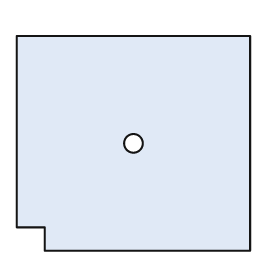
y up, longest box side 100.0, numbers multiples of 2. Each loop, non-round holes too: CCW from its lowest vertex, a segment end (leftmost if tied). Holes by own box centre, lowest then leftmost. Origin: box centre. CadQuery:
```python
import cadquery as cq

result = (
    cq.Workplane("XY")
    .moveTo(-38.0, -46.0)
    .lineTo(50.0, -46.0)
    .lineTo(50.0, 46.0)
    .lineTo(-50.0, 46.0)
    .lineTo(-50.0, -36.0)
    .lineTo(-38.0, -36.0)
    .close()
    .moveTo(0.0, 0.0)
    .circle(4.0)
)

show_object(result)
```